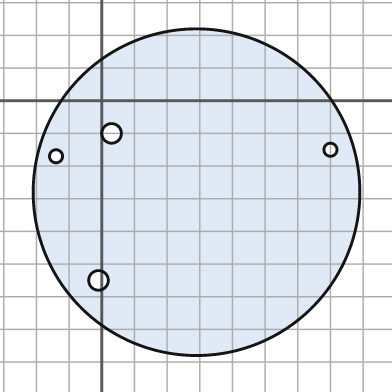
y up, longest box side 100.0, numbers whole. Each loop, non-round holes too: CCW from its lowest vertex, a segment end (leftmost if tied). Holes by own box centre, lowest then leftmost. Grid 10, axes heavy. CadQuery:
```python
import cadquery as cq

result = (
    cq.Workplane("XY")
    .moveTo(29.0, -28.0)
    .circle(50.0)
    .moveTo(-1.0, -55.0)
    .circle(3.0)
    .moveTo(-14.0, -17.0)
    .circle(2.0)
    .moveTo(70.0, -15.0)
    .circle(2.0)
    .moveTo(3.0, -10.0)
    .circle(3.0)
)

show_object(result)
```